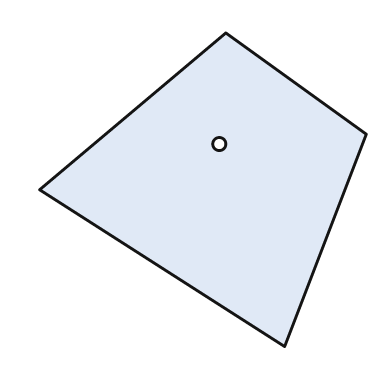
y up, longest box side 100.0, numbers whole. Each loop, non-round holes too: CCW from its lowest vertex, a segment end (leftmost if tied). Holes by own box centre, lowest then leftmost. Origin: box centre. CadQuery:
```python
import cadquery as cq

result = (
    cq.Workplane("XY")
    .moveTo(25.0, -48.0)
    .lineTo(50.0, 17.0)
    .lineTo(7.0, 48.0)
    .lineTo(-50.0, 0.0)
    .close()
    .moveTo(5.0, 14.0)
    .circle(2.0)
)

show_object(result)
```